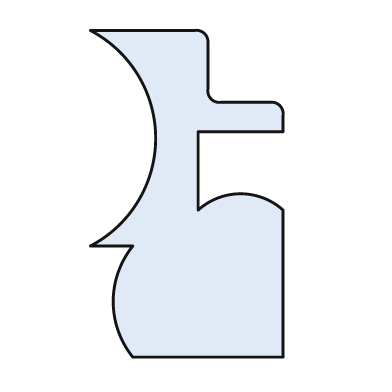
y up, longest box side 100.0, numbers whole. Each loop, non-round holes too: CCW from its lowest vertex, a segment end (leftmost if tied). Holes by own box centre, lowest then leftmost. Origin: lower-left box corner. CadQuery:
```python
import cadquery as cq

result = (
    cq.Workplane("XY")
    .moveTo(13.0, 0.0)
    .lineTo(59.0, 0.0)
    .lineTo(59.0, 45.0)
    .threePointArc((46.0, 50.0), (33.0, 45.0))
    .lineTo(33.0, 69.0)
    .lineTo(59.0, 69.0)
    .lineTo(59.0, 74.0)
    .threePointArc((58.0, 77.0), (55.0, 78.0))
    .lineTo(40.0, 78.0)
    .threePointArc((37.0, 79.0), (36.0, 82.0))
    .lineTo(36.0, 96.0)
    .threePointArc((35.0, 99.0), (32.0, 100.0))
    .lineTo(0.0, 100.0)
    .threePointArc((20.0, 67.0), (0.0, 34.0))
    .lineTo(13.0, 34.0)
    .threePointArc((7.0, 17.0), (13.0, 0.0))
    .close()
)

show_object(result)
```